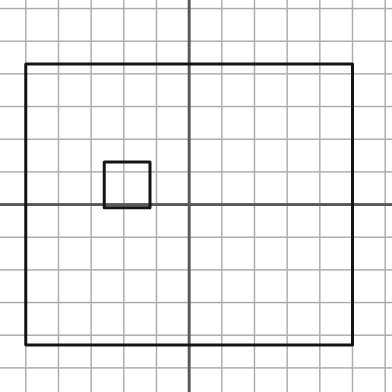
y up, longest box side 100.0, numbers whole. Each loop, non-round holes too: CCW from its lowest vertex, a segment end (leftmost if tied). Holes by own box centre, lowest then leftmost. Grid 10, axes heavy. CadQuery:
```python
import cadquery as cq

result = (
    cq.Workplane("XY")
    .moveTo(-50.0, -43.0)
    .lineTo(50.0, -43.0)
    .lineTo(50.0, 43.0)
    .lineTo(-50.0, 43.0)
    .close()
    .moveTo(-26.0, -1.0)
    .lineTo(-12.0, -1.0)
    .lineTo(-12.0, 13.0)
    .lineTo(-26.0, 13.0)
    .close()
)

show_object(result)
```